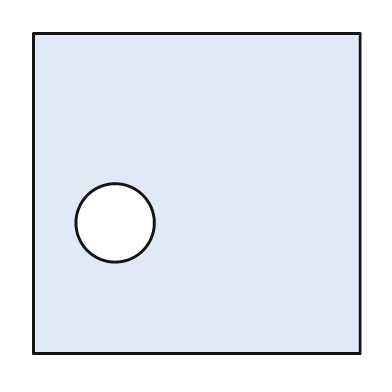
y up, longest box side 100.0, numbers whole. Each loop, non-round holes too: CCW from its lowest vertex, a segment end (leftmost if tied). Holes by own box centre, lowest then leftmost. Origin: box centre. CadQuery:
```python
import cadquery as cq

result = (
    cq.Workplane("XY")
    .moveTo(-50.0, -49.0)
    .lineTo(50.0, -49.0)
    .lineTo(50.0, 49.0)
    .lineTo(-50.0, 49.0)
    .close()
    .moveTo(-25.0, -9.0)
    .circle(12.0)
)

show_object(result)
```